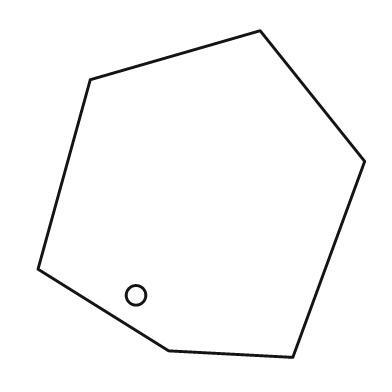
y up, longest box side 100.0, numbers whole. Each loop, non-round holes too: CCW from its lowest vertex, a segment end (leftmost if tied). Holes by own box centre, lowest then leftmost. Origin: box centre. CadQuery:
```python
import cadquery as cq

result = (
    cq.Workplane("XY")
    .moveTo(28.0, -50.0)
    .lineTo(50.0, 10.0)
    .lineTo(18.0, 50.0)
    .lineTo(-34.0, 35.0)
    .lineTo(-50.0, -23.0)
    .lineTo(-10.0, -48.0)
    .close()
    .moveTo(-20.0, -31.0)
    .circle(3.0)
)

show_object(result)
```